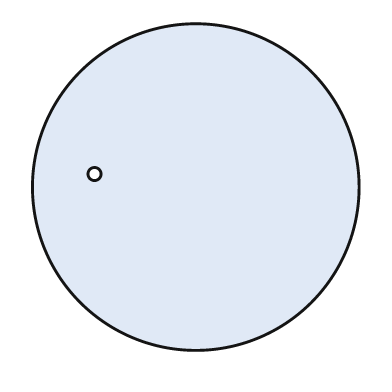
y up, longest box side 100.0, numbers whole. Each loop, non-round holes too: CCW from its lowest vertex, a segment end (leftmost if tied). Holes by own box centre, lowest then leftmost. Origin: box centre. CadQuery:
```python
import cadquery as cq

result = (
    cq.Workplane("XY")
    .moveTo(0.0, 0.0)
    .circle(50.0)
    .moveTo(-31.0, 4.0)
    .circle(2.0)
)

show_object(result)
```